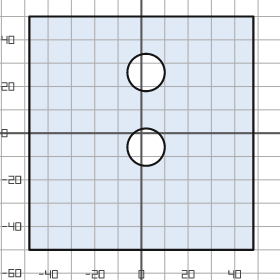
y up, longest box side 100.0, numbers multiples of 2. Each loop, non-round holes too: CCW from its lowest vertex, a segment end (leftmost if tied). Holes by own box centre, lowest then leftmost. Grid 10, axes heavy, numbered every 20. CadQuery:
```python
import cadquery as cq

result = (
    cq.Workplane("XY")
    .moveTo(-48.0, -50.0)
    .lineTo(48.0, -50.0)
    .lineTo(48.0, 50.0)
    .lineTo(-48.0, 50.0)
    .close()
    .moveTo(2.0, -6.0)
    .circle(8.0)
    .moveTo(2.0, 26.0)
    .circle(8.0)
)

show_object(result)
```